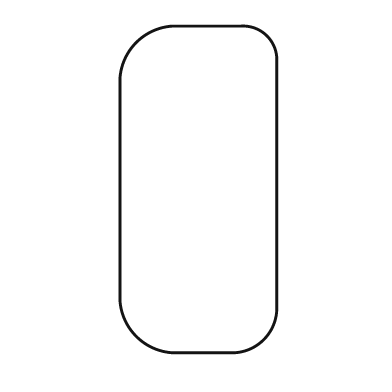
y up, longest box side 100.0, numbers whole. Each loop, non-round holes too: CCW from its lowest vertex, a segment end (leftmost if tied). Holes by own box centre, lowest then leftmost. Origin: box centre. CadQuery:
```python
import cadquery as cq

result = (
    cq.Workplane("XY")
    .moveTo(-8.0, -50.0)
    .lineTo(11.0, -50.0)
    .threePointArc((20.0, -46.0), (24.0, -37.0))
    .lineTo(24.0, 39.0)
    .threePointArc((21.0, 47.0), (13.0, 50.0))
    .lineTo(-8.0, 50.0)
    .threePointArc((-19.0, 45.0), (-24.0, 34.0))
    .lineTo(-24.0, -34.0)
    .threePointArc((-19.0, -45.0), (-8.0, -50.0))
    .close()
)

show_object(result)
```